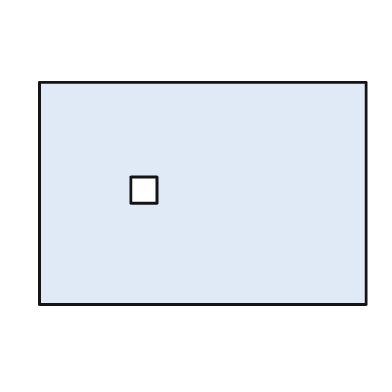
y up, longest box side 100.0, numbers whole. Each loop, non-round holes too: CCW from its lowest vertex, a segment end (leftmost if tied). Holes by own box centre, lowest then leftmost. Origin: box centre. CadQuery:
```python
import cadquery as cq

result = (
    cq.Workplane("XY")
    .moveTo(-50.0, -34.0)
    .lineTo(50.0, -34.0)
    .lineTo(50.0, 34.0)
    .lineTo(-50.0, 34.0)
    .close()
    .moveTo(-22.0, -3.0)
    .lineTo(-14.0, -3.0)
    .lineTo(-14.0, 5.0)
    .lineTo(-22.0, 5.0)
    .close()
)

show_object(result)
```